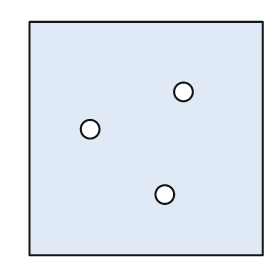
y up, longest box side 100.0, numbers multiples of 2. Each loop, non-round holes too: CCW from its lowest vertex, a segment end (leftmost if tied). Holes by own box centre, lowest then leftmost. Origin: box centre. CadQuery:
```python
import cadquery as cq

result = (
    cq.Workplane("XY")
    .moveTo(-50.0, -50.0)
    .lineTo(50.0, -50.0)
    .lineTo(50.0, 50.0)
    .lineTo(-50.0, 50.0)
    .close()
    .moveTo(8.0, -24.0)
    .circle(4.0)
    .moveTo(-24.0, 4.0)
    .circle(4.0)
    .moveTo(16.0, 20.0)
    .circle(4.0)
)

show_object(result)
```